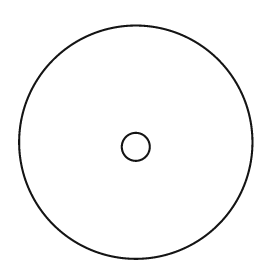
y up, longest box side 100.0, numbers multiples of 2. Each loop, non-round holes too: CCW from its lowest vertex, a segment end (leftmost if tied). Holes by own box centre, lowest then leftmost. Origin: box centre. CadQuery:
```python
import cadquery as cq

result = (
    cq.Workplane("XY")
    .moveTo(0.0, 0.0)
    .circle(50.0)
    .moveTo(0.0, -2.0)
    .circle(6.0)
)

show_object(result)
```